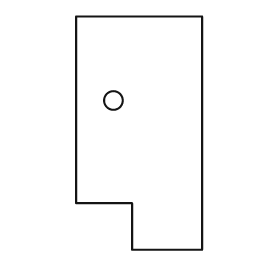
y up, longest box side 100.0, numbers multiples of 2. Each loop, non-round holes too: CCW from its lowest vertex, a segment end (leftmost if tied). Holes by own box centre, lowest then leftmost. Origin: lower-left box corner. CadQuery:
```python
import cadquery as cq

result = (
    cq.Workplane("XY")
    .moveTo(24.0, 0.0)
    .lineTo(54.0, 0.0)
    .lineTo(54.0, 100.0)
    .lineTo(0.0, 100.0)
    .lineTo(0.0, 20.0)
    .lineTo(24.0, 20.0)
    .close()
    .moveTo(16.0, 64.0)
    .circle(4.0)
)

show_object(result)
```